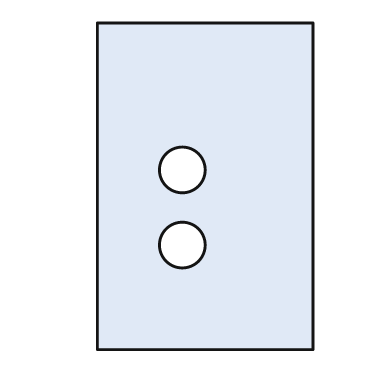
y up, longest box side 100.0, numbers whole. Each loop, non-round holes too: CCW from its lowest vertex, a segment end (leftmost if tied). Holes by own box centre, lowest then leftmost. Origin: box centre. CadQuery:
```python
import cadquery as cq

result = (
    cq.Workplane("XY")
    .moveTo(-33.0, -50.0)
    .lineTo(33.0, -50.0)
    .lineTo(33.0, 50.0)
    .lineTo(-33.0, 50.0)
    .close()
    .moveTo(-7.0, -18.0)
    .circle(7.0)
    .moveTo(-7.0, 5.0)
    .circle(7.0)
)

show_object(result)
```